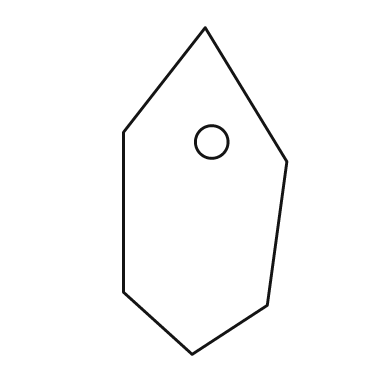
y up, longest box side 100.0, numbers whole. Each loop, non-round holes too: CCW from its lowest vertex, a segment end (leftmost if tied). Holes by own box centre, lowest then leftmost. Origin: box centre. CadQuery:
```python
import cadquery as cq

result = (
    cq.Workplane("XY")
    .moveTo(-4.0, -50.0)
    .lineTo(19.0, -35.0)
    .lineTo(25.0, 9.0)
    .lineTo(0.0, 50.0)
    .lineTo(-25.0, 18.0)
    .lineTo(-25.0, -31.0)
    .close()
    .moveTo(2.0, 15.0)
    .circle(5.0)
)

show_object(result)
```